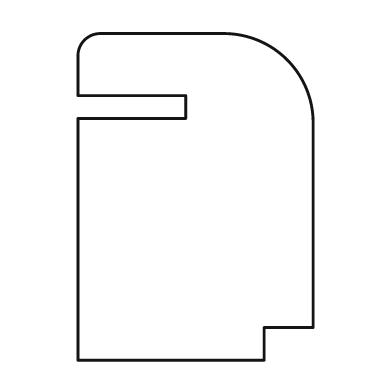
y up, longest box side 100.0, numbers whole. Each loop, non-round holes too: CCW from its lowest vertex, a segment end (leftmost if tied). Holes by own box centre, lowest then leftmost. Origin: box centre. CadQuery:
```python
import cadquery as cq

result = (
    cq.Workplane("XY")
    .moveTo(-36.0, -50.0)
    .lineTo(21.0, -50.0)
    .lineTo(21.0, -40.0)
    .lineTo(36.0, -40.0)
    .lineTo(36.0, 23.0)
    .threePointArc((28.0, 42.0), (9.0, 50.0))
    .lineTo(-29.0, 50.0)
    .threePointArc((-34.0, 48.0), (-36.0, 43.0))
    .lineTo(-36.0, 31.0)
    .lineTo(-3.0, 31.0)
    .lineTo(-3.0, 24.0)
    .lineTo(-36.0, 24.0)
    .close()
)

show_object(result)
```